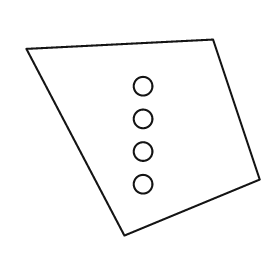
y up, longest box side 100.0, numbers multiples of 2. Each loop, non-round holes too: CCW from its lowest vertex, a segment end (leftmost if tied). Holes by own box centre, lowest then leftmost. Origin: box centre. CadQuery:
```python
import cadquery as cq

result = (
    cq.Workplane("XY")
    .moveTo(-8.0, -42.0)
    .lineTo(50.0, -18.0)
    .lineTo(30.0, 42.0)
    .lineTo(-50.0, 38.0)
    .close()
    .moveTo(0.0, -20.0)
    .circle(4.0)
    .moveTo(0.0, -6.0)
    .circle(4.0)
    .moveTo(0.0, 8.0)
    .circle(4.0)
    .moveTo(0.0, 22.0)
    .circle(4.0)
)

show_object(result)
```